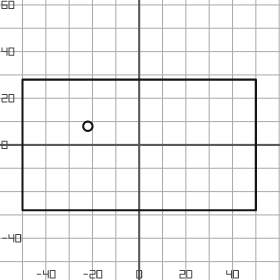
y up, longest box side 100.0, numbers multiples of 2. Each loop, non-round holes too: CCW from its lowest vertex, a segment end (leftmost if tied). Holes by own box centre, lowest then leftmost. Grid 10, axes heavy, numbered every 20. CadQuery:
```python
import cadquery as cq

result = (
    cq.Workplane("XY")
    .moveTo(-50.0, -28.0)
    .lineTo(50.0, -28.0)
    .lineTo(50.0, 28.0)
    .lineTo(-50.0, 28.0)
    .close()
    .moveTo(-22.0, 8.0)
    .circle(2.0)
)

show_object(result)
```